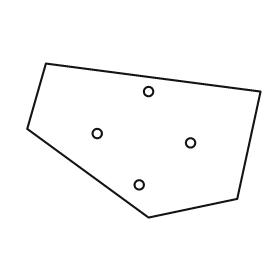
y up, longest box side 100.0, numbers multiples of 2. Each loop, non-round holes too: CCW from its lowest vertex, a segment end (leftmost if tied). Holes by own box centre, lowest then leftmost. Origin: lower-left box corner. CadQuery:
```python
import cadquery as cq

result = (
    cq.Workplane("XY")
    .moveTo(52.0, 0.0)
    .lineTo(90.0, 8.0)
    .lineTo(100.0, 54.0)
    .lineTo(8.0, 66.0)
    .lineTo(0.0, 38.0)
    .close()
    .moveTo(48.0, 14.0)
    .circle(2.0)
    .moveTo(70.0, 32.0)
    .circle(2.0)
    .moveTo(30.0, 36.0)
    .circle(2.0)
    .moveTo(52.0, 54.0)
    .circle(2.0)
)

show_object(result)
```